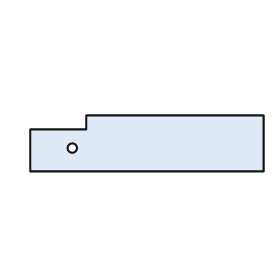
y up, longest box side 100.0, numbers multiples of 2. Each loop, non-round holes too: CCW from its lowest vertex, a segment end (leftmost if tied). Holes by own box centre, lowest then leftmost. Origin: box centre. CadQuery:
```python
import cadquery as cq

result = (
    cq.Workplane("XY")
    .moveTo(-50.0, -12.0)
    .lineTo(50.0, -12.0)
    .lineTo(50.0, 12.0)
    .lineTo(-26.0, 12.0)
    .lineTo(-26.0, 6.0)
    .lineTo(-50.0, 6.0)
    .close()
    .moveTo(-32.0, -2.0)
    .circle(2.0)
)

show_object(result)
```